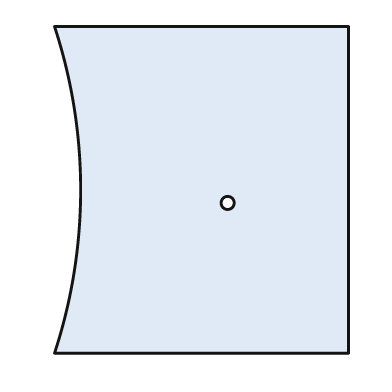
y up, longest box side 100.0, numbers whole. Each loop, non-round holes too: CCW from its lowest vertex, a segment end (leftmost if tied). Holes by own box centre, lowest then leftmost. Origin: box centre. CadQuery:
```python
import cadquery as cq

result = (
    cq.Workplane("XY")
    .moveTo(-45.0, -50.0)
    .lineTo(45.0, -50.0)
    .lineTo(45.0, 50.0)
    .lineTo(-45.0, 50.0)
    .threePointArc((-37.0, 0.0), (-45.0, -50.0))
    .close()
    .moveTo(8.0, -4.0)
    .circle(2.0)
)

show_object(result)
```